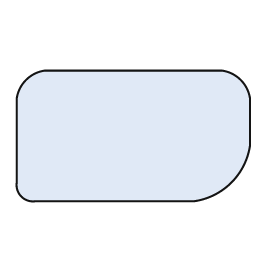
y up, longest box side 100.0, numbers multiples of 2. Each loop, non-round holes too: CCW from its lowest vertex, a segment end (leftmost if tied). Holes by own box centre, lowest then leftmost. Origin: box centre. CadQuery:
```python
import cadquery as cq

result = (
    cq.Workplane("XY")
    .moveTo(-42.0, -28.0)
    .lineTo(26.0, -28.0)
    .threePointArc((42.0, -20.0), (50.0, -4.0))
    .lineTo(50.0, 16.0)
    .threePointArc((46.0, 24.0), (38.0, 28.0))
    .lineTo(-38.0, 28.0)
    .threePointArc((-46.0, 24.0), (-50.0, 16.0))
    .lineTo(-50.0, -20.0)
    .threePointArc((-48.0, -26.0), (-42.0, -28.0))
    .close()
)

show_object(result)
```